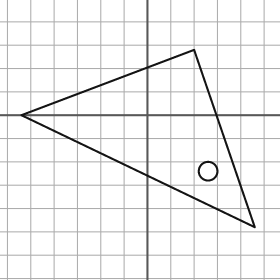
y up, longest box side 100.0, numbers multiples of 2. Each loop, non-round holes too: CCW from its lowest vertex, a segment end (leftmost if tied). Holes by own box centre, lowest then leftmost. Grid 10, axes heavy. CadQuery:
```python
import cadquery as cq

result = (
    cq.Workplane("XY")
    .moveTo(46.0, -48.0)
    .lineTo(20.0, 28.0)
    .lineTo(-54.0, 0.0)
    .close()
    .moveTo(26.0, -24.0)
    .circle(4.0)
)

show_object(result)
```